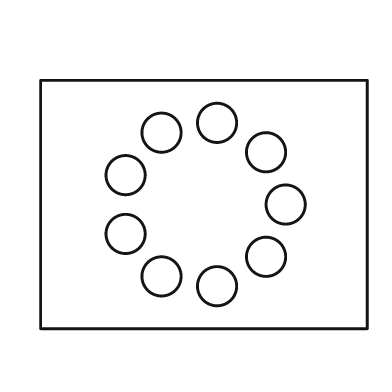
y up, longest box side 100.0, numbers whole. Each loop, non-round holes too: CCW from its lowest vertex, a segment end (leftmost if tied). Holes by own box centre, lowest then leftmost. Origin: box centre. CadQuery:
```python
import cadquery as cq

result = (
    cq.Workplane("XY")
    .moveTo(-50.0, -38.0)
    .lineTo(50.0, -38.0)
    .lineTo(50.0, 38.0)
    .lineTo(-50.0, 38.0)
    .close()
    .moveTo(4.0, -25.0)
    .circle(6.0)
    .moveTo(-13.0, -22.0)
    .circle(6.0)
    .moveTo(19.0, -16.0)
    .circle(6.0)
    .moveTo(-24.0, -9.0)
    .circle(6.0)
    .moveTo(25.0, 0.0)
    .circle(6.0)
    .moveTo(-24.0, 9.0)
    .circle(6.0)
    .moveTo(19.0, 16.0)
    .circle(6.0)
    .moveTo(-13.0, 22.0)
    .circle(6.0)
    .moveTo(4.0, 25.0)
    .circle(6.0)
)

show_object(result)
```